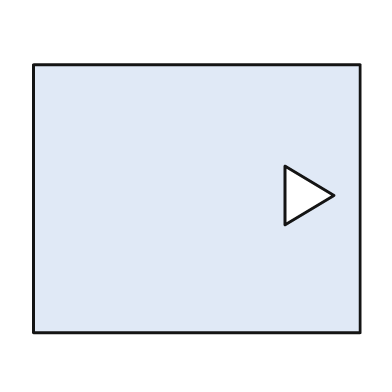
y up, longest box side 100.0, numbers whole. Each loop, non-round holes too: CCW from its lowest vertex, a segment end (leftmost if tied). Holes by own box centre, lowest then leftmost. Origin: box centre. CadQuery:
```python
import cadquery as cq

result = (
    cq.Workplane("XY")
    .moveTo(-50.0, -41.0)
    .lineTo(50.0, -41.0)
    .lineTo(50.0, 41.0)
    .lineTo(-50.0, 41.0)
    .close()
    .moveTo(27.0, -8.0)
    .lineTo(42.0, 1.0)
    .lineTo(27.0, 10.0)
    .close()
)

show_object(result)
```